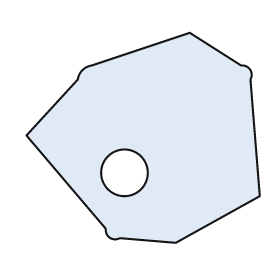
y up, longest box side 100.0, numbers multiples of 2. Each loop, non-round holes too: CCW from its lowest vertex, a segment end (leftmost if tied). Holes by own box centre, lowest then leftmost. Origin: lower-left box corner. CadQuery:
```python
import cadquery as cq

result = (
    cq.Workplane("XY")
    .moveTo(64.0, 0.0)
    .lineTo(100.0, 20.0)
    .lineTo(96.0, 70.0)
    .threePointArc((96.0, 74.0), (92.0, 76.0))
    .lineTo(70.0, 90.0)
    .lineTo(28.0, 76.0)
    .threePointArc((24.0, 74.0), (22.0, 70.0))
    .lineTo(0.0, 46.0)
    .lineTo(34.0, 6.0)
    .threePointArc((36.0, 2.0), (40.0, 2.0))
    .close()
    .moveTo(42.0, 30.0)
    .circle(10.0)
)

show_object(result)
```